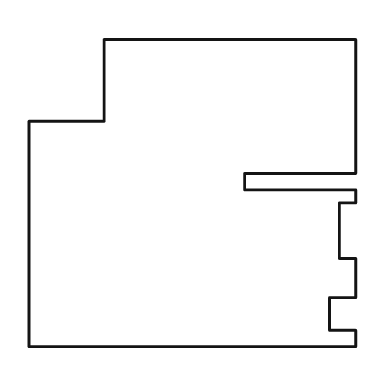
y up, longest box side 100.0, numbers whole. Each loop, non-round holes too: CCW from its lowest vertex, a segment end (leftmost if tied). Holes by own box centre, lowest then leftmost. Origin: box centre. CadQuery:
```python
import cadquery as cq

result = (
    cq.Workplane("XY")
    .moveTo(-50.0, -47.0)
    .lineTo(50.0, -47.0)
    .lineTo(50.0, -42.0)
    .lineTo(42.0, -42.0)
    .lineTo(42.0, -32.0)
    .lineTo(50.0, -32.0)
    .lineTo(50.0, -20.0)
    .lineTo(45.0, -20.0)
    .lineTo(45.0, -3.0)
    .lineTo(50.0, -3.0)
    .lineTo(50.0, 1.0)
    .lineTo(16.0, 1.0)
    .lineTo(16.0, 6.0)
    .lineTo(50.0, 6.0)
    .lineTo(50.0, 47.0)
    .lineTo(-27.0, 47.0)
    .lineTo(-27.0, 22.0)
    .lineTo(-50.0, 22.0)
    .close()
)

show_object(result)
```